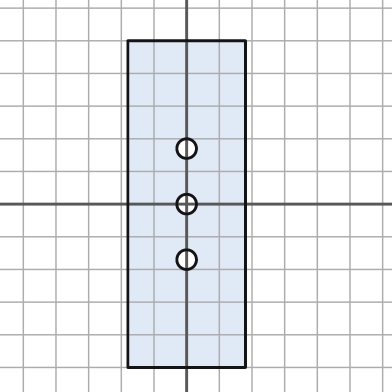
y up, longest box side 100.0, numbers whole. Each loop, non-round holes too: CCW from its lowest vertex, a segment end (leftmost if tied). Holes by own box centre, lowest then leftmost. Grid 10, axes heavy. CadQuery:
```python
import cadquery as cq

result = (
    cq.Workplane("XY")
    .moveTo(-18.0, -50.0)
    .lineTo(18.0, -50.0)
    .lineTo(18.0, 50.0)
    .lineTo(-18.0, 50.0)
    .close()
    .moveTo(0.0, -17.0)
    .circle(3.0)
    .moveTo(0.0, 0.0)
    .circle(3.0)
    .moveTo(0.0, 17.0)
    .circle(3.0)
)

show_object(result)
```